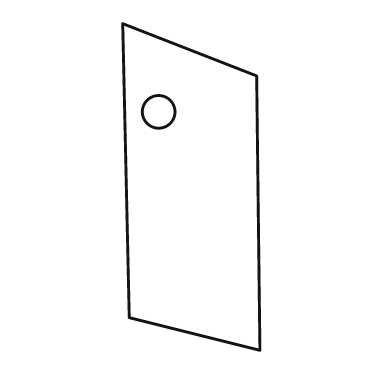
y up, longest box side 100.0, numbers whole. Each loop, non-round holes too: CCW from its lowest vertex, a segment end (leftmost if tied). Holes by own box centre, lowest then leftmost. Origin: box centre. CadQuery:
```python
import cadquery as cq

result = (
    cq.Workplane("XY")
    .moveTo(21.0, -50.0)
    .lineTo(20.0, 34.0)
    .lineTo(-21.0, 50.0)
    .lineTo(-19.0, -40.0)
    .close()
    .moveTo(-10.0, 23.0)
    .circle(5.0)
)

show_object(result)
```